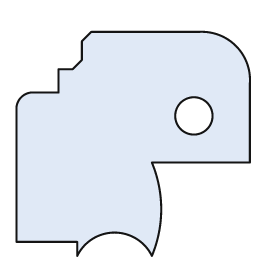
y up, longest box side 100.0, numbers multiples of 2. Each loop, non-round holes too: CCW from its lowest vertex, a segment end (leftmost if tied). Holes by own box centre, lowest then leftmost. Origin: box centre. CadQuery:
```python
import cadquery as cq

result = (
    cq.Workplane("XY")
    .moveTo(-24.0, -48.0)
    .threePointArc((-8.0, -38.0), (8.0, -48.0))
    .threePointArc((12.0, -28.0), (8.0, -8.0))
    .lineTo(50.0, -8.0)
    .lineTo(50.0, 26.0)
    .threePointArc((44.0, 42.0), (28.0, 48.0))
    .lineTo(-18.0, 48.0)
    .lineTo(-22.0, 44.0)
    .lineTo(-22.0, 36.0)
    .lineTo(-26.0, 32.0)
    .lineTo(-32.0, 32.0)
    .lineTo(-32.0, 22.0)
    .lineTo(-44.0, 22.0)
    .threePointArc((-48.0, 20.0), (-50.0, 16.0))
    .lineTo(-50.0, -42.0)
    .lineTo(-24.0, -42.0)
    .close()
    .moveTo(26.0, 12.0)
    .circle(8.0)
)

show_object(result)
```